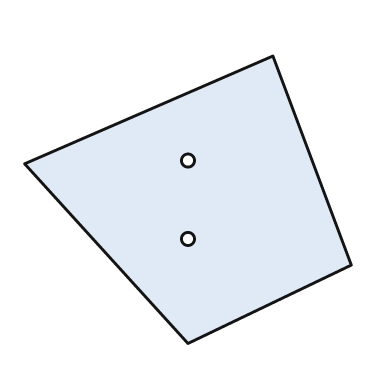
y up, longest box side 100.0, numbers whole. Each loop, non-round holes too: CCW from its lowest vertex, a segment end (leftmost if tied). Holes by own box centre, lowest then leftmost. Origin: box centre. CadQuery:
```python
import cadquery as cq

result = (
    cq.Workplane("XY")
    .moveTo(0.0, -44.0)
    .lineTo(50.0, -20.0)
    .lineTo(26.0, 44.0)
    .lineTo(-50.0, 11.0)
    .close()
    .moveTo(0.0, -12.0)
    .circle(2.0)
    .moveTo(0.0, 12.0)
    .circle(2.0)
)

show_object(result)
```